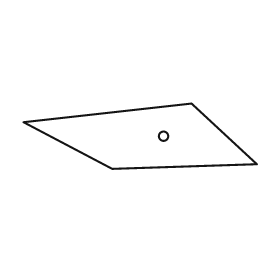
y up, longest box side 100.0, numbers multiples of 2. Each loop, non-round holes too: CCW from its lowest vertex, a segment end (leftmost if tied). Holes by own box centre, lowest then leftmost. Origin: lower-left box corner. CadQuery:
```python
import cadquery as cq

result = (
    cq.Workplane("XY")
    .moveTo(38.0, 0.0)
    .lineTo(100.0, 2.0)
    .lineTo(72.0, 28.0)
    .lineTo(0.0, 20.0)
    .close()
    .moveTo(60.0, 14.0)
    .circle(2.0)
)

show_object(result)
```